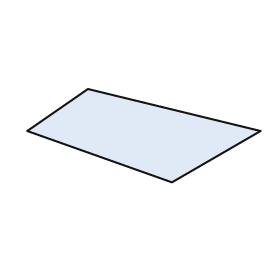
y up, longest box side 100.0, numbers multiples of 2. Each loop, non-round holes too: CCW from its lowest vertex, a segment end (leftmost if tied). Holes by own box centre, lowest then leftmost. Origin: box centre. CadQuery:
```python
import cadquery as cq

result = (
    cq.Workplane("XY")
    .moveTo(12.0, -20.0)
    .lineTo(50.0, 2.0)
    .lineTo(-24.0, 20.0)
    .lineTo(-50.0, 2.0)
    .close()
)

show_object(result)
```